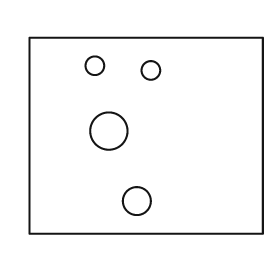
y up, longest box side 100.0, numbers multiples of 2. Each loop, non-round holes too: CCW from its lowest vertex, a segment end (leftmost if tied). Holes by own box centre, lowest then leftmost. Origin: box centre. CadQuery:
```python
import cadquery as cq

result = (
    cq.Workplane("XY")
    .moveTo(-50.0, -42.0)
    .lineTo(50.0, -42.0)
    .lineTo(50.0, 42.0)
    .lineTo(-50.0, 42.0)
    .close()
    .moveTo(-4.0, -28.0)
    .circle(6.0)
    .moveTo(-16.0, 2.0)
    .circle(8.0)
    .moveTo(2.0, 28.0)
    .circle(4.0)
    .moveTo(-22.0, 30.0)
    .circle(4.0)
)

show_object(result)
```